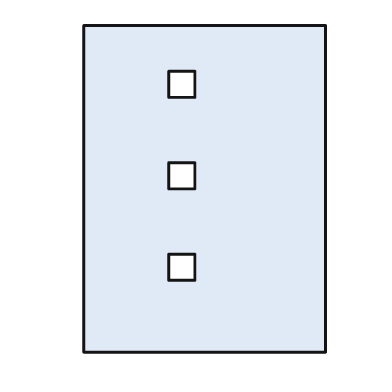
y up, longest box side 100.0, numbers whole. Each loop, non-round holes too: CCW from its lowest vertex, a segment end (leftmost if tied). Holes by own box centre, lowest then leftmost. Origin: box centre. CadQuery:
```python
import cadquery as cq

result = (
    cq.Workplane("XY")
    .moveTo(-37.0, -50.0)
    .lineTo(37.0, -50.0)
    .lineTo(37.0, 50.0)
    .lineTo(-37.0, 50.0)
    .close()
    .moveTo(-11.0, -28.0)
    .lineTo(-3.0, -28.0)
    .lineTo(-3.0, -20.0)
    .lineTo(-11.0, -20.0)
    .close()
    .moveTo(-11.0, 0.0)
    .lineTo(-3.0, 0.0)
    .lineTo(-3.0, 8.0)
    .lineTo(-11.0, 8.0)
    .close()
    .moveTo(-11.0, 28.0)
    .lineTo(-3.0, 28.0)
    .lineTo(-3.0, 36.0)
    .lineTo(-11.0, 36.0)
    .close()
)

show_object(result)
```